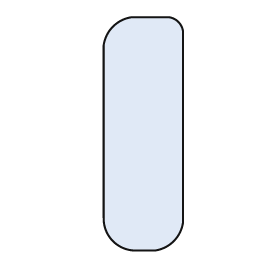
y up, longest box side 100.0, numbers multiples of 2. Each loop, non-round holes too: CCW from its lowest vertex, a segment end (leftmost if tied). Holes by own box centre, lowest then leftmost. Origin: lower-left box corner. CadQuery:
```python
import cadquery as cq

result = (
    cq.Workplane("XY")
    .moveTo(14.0, 0.0)
    .lineTo(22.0, 0.0)
    .threePointArc((30.0, 4.0), (34.0, 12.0))
    .lineTo(34.0, 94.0)
    .threePointArc((32.0, 98.0), (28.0, 100.0))
    .lineTo(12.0, 100.0)
    .threePointArc((4.0, 96.0), (0.0, 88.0))
    .lineTo(0.0, 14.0)
    .threePointArc((4.0, 4.0), (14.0, 0.0))
    .close()
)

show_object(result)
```